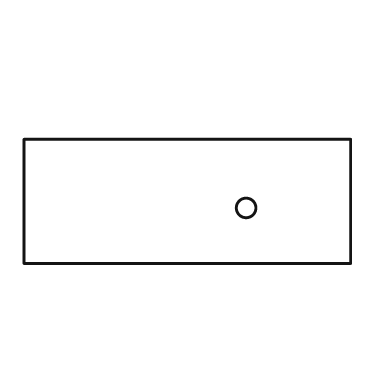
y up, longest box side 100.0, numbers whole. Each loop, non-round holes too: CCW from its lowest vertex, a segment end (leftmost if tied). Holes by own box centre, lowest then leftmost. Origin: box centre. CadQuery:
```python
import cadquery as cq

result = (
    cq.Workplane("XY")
    .moveTo(-50.0, -19.0)
    .lineTo(50.0, -19.0)
    .lineTo(50.0, 19.0)
    .lineTo(-50.0, 19.0)
    .close()
    .moveTo(18.0, -2.0)
    .circle(3.0)
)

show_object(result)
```